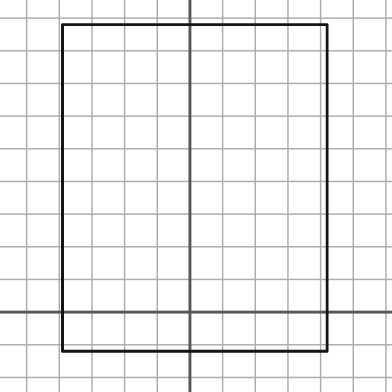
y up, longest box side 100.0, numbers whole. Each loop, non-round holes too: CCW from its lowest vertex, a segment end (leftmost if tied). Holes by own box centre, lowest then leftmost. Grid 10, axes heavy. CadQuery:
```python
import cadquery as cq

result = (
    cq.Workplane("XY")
    .moveTo(-39.0, -12.0)
    .lineTo(42.0, -12.0)
    .lineTo(42.0, 88.0)
    .lineTo(-39.0, 88.0)
    .close()
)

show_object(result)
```